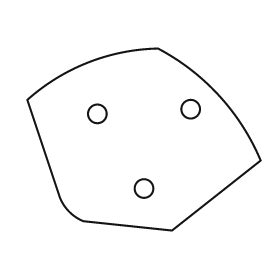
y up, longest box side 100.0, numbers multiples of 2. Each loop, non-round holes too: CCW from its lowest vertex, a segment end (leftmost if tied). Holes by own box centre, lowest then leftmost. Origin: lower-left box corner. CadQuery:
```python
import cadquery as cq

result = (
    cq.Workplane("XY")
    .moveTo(62.0, 0.0)
    .lineTo(100.0, 30.0)
    .threePointArc((82.0, 58.0), (56.0, 78.0))
    .threePointArc((26.0, 72.0), (0.0, 56.0))
    .lineTo(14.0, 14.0)
    .threePointArc((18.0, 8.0), (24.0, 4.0))
    .close()
    .moveTo(50.0, 18.0)
    .circle(4.0)
    .moveTo(30.0, 50.0)
    .circle(4.0)
    .moveTo(70.0, 52.0)
    .circle(4.0)
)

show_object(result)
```